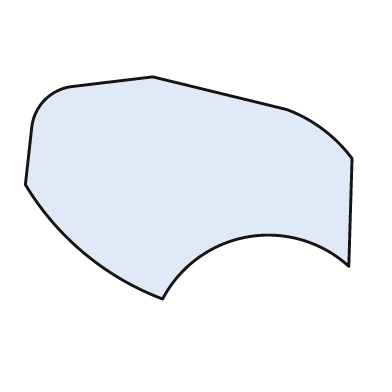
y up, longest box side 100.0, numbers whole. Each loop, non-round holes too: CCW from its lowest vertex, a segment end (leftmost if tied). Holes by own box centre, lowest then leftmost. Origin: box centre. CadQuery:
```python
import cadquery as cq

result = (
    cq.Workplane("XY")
    .moveTo(-8.0, -34.0)
    .threePointArc((18.0, -15.0), (49.0, -24.0))
    .lineTo(50.0, 9.0)
    .threePointArc((41.0, 18.0), (30.0, 24.0))
    .lineTo(-11.0, 34.0)
    .lineTo(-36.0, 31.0)
    .threePointArc((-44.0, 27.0), (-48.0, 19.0))
    .lineTo(-50.0, 1.0)
    .threePointArc((-32.0, -20.0), (-8.0, -34.0))
    .close()
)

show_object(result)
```